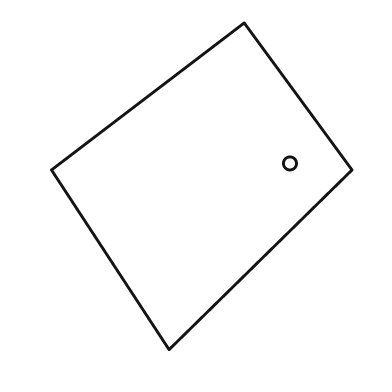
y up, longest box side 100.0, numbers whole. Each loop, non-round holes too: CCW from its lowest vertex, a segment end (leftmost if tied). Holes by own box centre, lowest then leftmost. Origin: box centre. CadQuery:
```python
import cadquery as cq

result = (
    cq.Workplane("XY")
    .moveTo(-10.0, -50.0)
    .lineTo(46.0, 5.0)
    .lineTo(13.0, 50.0)
    .lineTo(-46.0, 5.0)
    .close()
    .moveTo(27.0, 7.0)
    .circle(2.0)
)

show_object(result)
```